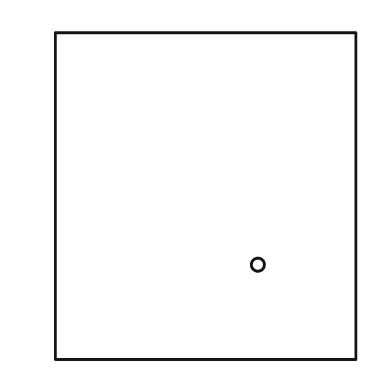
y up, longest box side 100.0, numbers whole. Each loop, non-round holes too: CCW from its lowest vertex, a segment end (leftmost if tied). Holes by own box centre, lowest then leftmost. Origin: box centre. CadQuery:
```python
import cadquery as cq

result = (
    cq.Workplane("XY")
    .moveTo(-46.0, -50.0)
    .lineTo(46.0, -50.0)
    .lineTo(46.0, 50.0)
    .lineTo(-46.0, 50.0)
    .close()
    .moveTo(16.0, -21.0)
    .circle(2.0)
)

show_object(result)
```